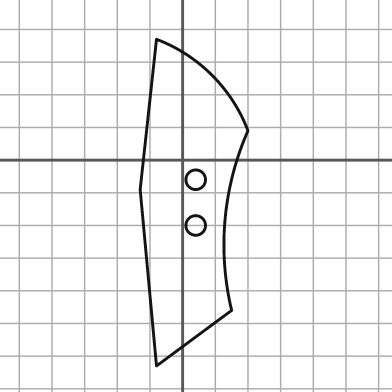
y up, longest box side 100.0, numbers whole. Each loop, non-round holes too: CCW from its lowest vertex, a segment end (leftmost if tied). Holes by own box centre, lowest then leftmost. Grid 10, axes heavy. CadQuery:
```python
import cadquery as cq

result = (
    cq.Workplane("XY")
    .moveTo(-8.0, -63.0)
    .lineTo(15.0, -46.0)
    .threePointArc((13.0, -18.0), (20.0, 9.0))
    .threePointArc((9.0, 26.0), (-8.0, 37.0))
    .lineTo(-13.0, -9.0)
    .close()
    .moveTo(4.0, -20.0)
    .circle(3.0)
    .moveTo(4.0, -6.0)
    .circle(3.0)
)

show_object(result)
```